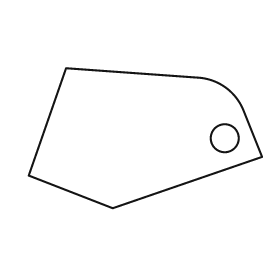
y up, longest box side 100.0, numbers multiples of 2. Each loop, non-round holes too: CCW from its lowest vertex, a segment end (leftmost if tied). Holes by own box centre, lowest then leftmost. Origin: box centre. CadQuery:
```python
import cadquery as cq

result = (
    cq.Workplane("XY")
    .moveTo(-14.0, -30.0)
    .lineTo(50.0, -8.0)
    .lineTo(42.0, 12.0)
    .threePointArc((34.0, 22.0), (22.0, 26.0))
    .lineTo(-34.0, 30.0)
    .lineTo(-50.0, -16.0)
    .close()
    .moveTo(34.0, 0.0)
    .circle(6.0)
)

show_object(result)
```